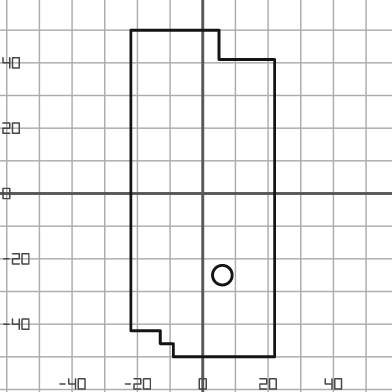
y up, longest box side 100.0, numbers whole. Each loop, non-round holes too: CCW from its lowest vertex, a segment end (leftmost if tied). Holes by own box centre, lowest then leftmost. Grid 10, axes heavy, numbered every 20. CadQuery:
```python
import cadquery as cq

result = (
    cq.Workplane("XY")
    .moveTo(-9.0, -50.0)
    .lineTo(22.0, -50.0)
    .lineTo(22.0, 41.0)
    .lineTo(5.0, 41.0)
    .lineTo(5.0, 50.0)
    .lineTo(-22.0, 50.0)
    .lineTo(-22.0, -42.0)
    .lineTo(-13.0, -42.0)
    .lineTo(-13.0, -46.0)
    .lineTo(-9.0, -46.0)
    .close()
    .moveTo(6.0, -25.0)
    .circle(3.0)
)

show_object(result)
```